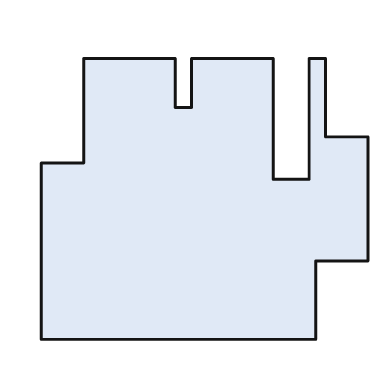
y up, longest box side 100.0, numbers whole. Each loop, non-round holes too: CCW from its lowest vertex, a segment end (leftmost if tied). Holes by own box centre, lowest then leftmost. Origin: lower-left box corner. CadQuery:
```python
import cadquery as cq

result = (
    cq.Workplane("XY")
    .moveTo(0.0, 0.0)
    .lineTo(84.0, 0.0)
    .lineTo(84.0, 24.0)
    .lineTo(100.0, 24.0)
    .lineTo(100.0, 62.0)
    .lineTo(87.0, 62.0)
    .lineTo(87.0, 86.0)
    .lineTo(82.0, 86.0)
    .lineTo(82.0, 49.0)
    .lineTo(71.0, 49.0)
    .lineTo(71.0, 86.0)
    .lineTo(46.0, 86.0)
    .lineTo(46.0, 71.0)
    .lineTo(41.0, 71.0)
    .lineTo(41.0, 86.0)
    .lineTo(13.0, 86.0)
    .lineTo(13.0, 54.0)
    .lineTo(0.0, 54.0)
    .close()
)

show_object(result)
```